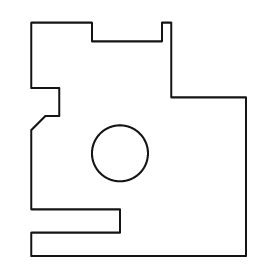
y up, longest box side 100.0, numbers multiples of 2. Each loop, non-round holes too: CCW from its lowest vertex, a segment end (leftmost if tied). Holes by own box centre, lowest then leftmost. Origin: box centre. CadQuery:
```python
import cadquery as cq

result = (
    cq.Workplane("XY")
    .moveTo(-46.0, -50.0)
    .lineTo(46.0, -50.0)
    .lineTo(46.0, 18.0)
    .lineTo(14.0, 18.0)
    .lineTo(14.0, 50.0)
    .lineTo(10.0, 50.0)
    .lineTo(10.0, 42.0)
    .lineTo(-20.0, 42.0)
    .lineTo(-20.0, 50.0)
    .lineTo(-46.0, 50.0)
    .lineTo(-46.0, 22.0)
    .lineTo(-34.0, 22.0)
    .lineTo(-34.0, 10.0)
    .lineTo(-40.0, 10.0)
    .lineTo(-46.0, 4.0)
    .lineTo(-46.0, -30.0)
    .lineTo(-8.0, -30.0)
    .lineTo(-8.0, -40.0)
    .lineTo(-46.0, -40.0)
    .close()
    .moveTo(-8.0, -6.0)
    .circle(12.0)
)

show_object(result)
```